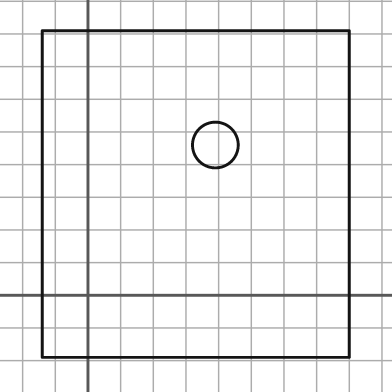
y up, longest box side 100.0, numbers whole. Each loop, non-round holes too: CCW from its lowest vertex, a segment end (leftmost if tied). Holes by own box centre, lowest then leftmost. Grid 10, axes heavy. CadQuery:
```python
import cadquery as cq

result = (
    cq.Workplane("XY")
    .moveTo(-14.0, -19.0)
    .lineTo(80.0, -19.0)
    .lineTo(80.0, 81.0)
    .lineTo(-14.0, 81.0)
    .close()
    .moveTo(39.0, 46.0)
    .circle(7.0)
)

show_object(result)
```